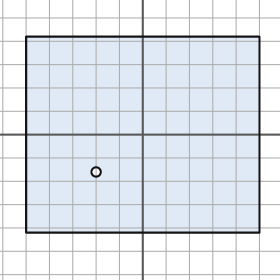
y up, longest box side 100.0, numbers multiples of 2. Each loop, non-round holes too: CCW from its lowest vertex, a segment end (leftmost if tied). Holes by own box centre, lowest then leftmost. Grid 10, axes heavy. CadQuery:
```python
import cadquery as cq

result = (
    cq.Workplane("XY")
    .moveTo(-50.0, -42.0)
    .lineTo(50.0, -42.0)
    .lineTo(50.0, 42.0)
    .lineTo(-50.0, 42.0)
    .close()
    .moveTo(-20.0, -16.0)
    .circle(2.0)
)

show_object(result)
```